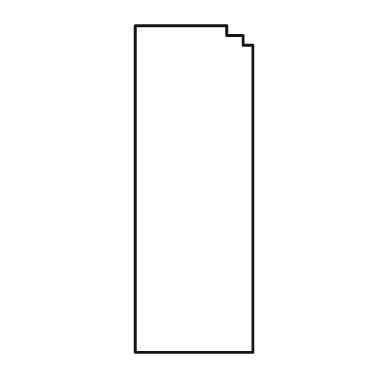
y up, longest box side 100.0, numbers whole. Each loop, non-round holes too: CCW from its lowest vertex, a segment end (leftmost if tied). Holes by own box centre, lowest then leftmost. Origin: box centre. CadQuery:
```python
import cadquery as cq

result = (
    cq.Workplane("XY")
    .moveTo(-18.0, -50.0)
    .lineTo(18.0, -50.0)
    .lineTo(18.0, 44.0)
    .lineTo(15.0, 44.0)
    .lineTo(15.0, 47.0)
    .lineTo(10.0, 47.0)
    .lineTo(10.0, 50.0)
    .lineTo(-18.0, 50.0)
    .close()
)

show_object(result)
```